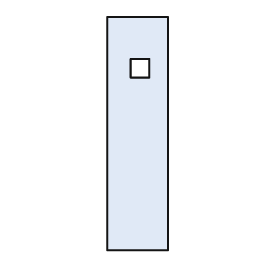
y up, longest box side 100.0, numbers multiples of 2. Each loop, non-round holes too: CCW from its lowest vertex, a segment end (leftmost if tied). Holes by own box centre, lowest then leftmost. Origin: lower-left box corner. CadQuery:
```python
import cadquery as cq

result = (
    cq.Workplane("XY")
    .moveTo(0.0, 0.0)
    .lineTo(26.0, 0.0)
    .lineTo(26.0, 100.0)
    .lineTo(0.0, 100.0)
    .close()
    .moveTo(10.0, 74.0)
    .lineTo(18.0, 74.0)
    .lineTo(18.0, 82.0)
    .lineTo(10.0, 82.0)
    .close()
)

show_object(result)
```